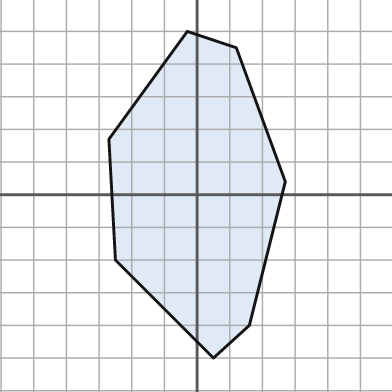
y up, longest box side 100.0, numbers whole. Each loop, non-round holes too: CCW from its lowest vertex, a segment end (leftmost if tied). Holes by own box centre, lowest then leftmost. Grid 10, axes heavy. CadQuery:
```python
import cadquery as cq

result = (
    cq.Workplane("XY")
    .moveTo(5.0, -50.0)
    .lineTo(16.0, -40.0)
    .lineTo(27.0, 4.0)
    .lineTo(12.0, 45.0)
    .lineTo(-3.0, 50.0)
    .lineTo(-27.0, 17.0)
    .lineTo(-25.0, -20.0)
    .close()
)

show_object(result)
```